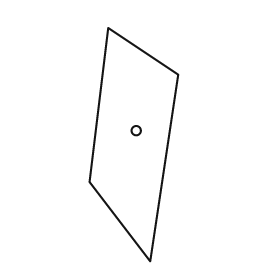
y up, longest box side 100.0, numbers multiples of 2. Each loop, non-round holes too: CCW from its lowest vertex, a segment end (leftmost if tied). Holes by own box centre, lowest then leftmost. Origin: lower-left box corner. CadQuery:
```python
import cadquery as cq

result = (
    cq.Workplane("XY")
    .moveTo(26.0, 0.0)
    .lineTo(38.0, 80.0)
    .lineTo(8.0, 100.0)
    .lineTo(0.0, 34.0)
    .close()
    .moveTo(20.0, 56.0)
    .circle(2.0)
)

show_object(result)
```